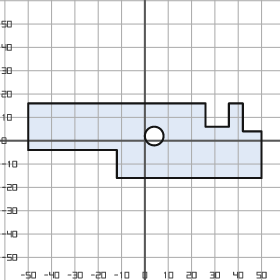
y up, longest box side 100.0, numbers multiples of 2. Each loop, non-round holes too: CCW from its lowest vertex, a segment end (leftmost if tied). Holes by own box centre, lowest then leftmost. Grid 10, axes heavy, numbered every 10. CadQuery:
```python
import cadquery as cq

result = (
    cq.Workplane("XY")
    .moveTo(-12.0, -16.0)
    .lineTo(50.0, -16.0)
    .lineTo(50.0, 4.0)
    .lineTo(42.0, 4.0)
    .lineTo(42.0, 16.0)
    .lineTo(36.0, 16.0)
    .lineTo(36.0, 6.0)
    .lineTo(26.0, 6.0)
    .lineTo(26.0, 16.0)
    .lineTo(-50.0, 16.0)
    .lineTo(-50.0, -4.0)
    .lineTo(-12.0, -4.0)
    .close()
    .moveTo(4.0, 2.0)
    .circle(4.0)
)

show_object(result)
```